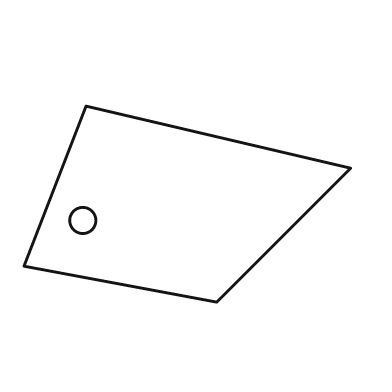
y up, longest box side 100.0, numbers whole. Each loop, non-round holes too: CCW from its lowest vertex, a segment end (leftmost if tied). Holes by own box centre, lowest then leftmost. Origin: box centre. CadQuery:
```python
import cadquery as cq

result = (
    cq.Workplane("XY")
    .moveTo(9.0, -30.0)
    .lineTo(50.0, 11.0)
    .lineTo(-31.0, 30.0)
    .lineTo(-50.0, -19.0)
    .close()
    .moveTo(-32.0, -5.0)
    .circle(4.0)
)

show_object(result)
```